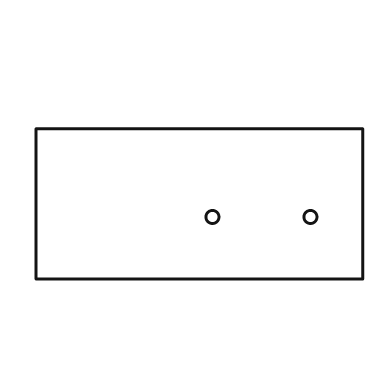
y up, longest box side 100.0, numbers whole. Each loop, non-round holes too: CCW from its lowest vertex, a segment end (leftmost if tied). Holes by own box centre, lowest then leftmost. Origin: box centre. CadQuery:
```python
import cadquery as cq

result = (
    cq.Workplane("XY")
    .moveTo(-50.0, -23.0)
    .lineTo(50.0, -23.0)
    .lineTo(50.0, 23.0)
    .lineTo(-50.0, 23.0)
    .close()
    .moveTo(4.0, -4.0)
    .circle(2.0)
    .moveTo(34.0, -4.0)
    .circle(2.0)
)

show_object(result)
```